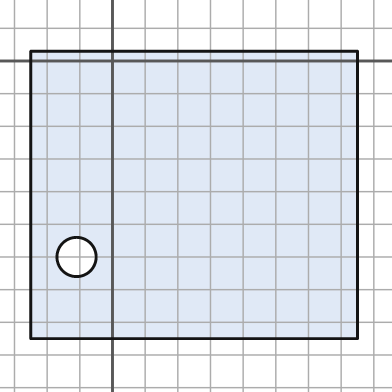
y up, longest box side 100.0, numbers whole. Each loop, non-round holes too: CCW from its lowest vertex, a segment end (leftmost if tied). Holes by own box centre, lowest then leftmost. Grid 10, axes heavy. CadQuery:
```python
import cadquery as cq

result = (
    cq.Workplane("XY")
    .moveTo(-25.0, -85.0)
    .lineTo(75.0, -85.0)
    .lineTo(75.0, 3.0)
    .lineTo(-25.0, 3.0)
    .close()
    .moveTo(-11.0, -60.0)
    .circle(6.0)
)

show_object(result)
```